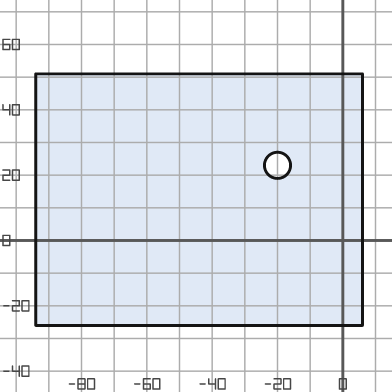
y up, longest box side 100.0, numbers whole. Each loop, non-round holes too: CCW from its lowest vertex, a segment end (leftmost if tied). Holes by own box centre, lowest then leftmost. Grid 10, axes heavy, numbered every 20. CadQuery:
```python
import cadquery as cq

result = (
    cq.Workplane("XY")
    .moveTo(-94.0, -26.0)
    .lineTo(6.0, -26.0)
    .lineTo(6.0, 51.0)
    .lineTo(-94.0, 51.0)
    .close()
    .moveTo(-20.0, 23.0)
    .circle(4.0)
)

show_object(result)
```